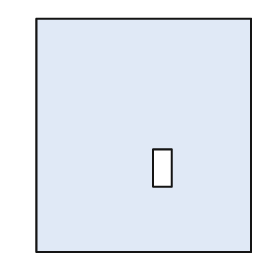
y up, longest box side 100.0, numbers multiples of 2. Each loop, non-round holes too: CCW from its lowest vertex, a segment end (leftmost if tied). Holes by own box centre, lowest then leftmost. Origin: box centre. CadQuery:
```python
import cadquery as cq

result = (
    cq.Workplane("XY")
    .moveTo(-46.0, -50.0)
    .lineTo(46.0, -50.0)
    .lineTo(46.0, 50.0)
    .lineTo(-46.0, 50.0)
    .close()
    .moveTo(4.0, -22.0)
    .lineTo(12.0, -22.0)
    .lineTo(12.0, -6.0)
    .lineTo(4.0, -6.0)
    .close()
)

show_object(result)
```